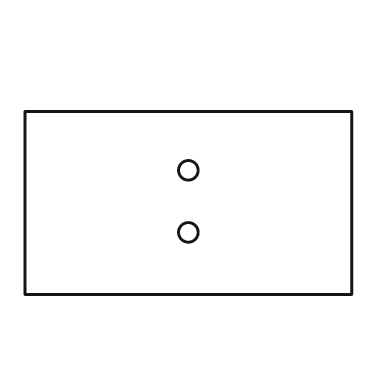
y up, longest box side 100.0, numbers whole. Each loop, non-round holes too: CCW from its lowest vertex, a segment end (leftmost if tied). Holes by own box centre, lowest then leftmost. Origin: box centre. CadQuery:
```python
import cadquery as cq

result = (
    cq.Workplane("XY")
    .moveTo(-50.0, -28.0)
    .lineTo(50.0, -28.0)
    .lineTo(50.0, 28.0)
    .lineTo(-50.0, 28.0)
    .close()
    .moveTo(0.0, -9.0)
    .circle(3.0)
    .moveTo(0.0, 10.0)
    .circle(3.0)
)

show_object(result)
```